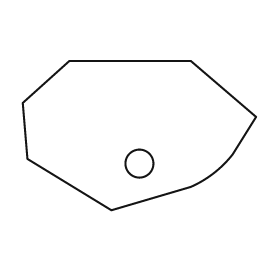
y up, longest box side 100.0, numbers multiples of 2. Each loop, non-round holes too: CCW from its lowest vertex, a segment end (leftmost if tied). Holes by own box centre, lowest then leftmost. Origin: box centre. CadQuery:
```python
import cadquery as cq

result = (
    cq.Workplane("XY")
    .moveTo(-12.0, -32.0)
    .lineTo(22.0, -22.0)
    .threePointArc((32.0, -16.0), (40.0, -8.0))
    .lineTo(50.0, 8.0)
    .lineTo(22.0, 32.0)
    .lineTo(-30.0, 32.0)
    .lineTo(-50.0, 14.0)
    .lineTo(-48.0, -10.0)
    .close()
    .moveTo(0.0, -12.0)
    .circle(6.0)
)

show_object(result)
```